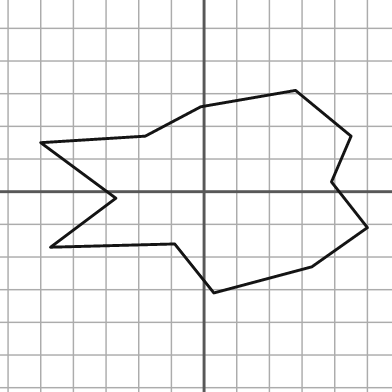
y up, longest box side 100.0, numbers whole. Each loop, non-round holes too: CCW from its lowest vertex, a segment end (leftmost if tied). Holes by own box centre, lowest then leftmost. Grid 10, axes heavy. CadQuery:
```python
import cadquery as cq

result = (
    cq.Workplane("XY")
    .moveTo(3.0, -31.0)
    .lineTo(33.0, -23.0)
    .lineTo(50.0, -11.0)
    .lineTo(39.0, 3.0)
    .lineTo(45.0, 17.0)
    .lineTo(28.0, 31.0)
    .lineTo(-1.0, 26.0)
    .lineTo(-18.0, 17.0)
    .lineTo(-50.0, 15.0)
    .lineTo(-27.0, -2.0)
    .lineTo(-47.0, -17.0)
    .lineTo(-9.0, -16.0)
    .close()
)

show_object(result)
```